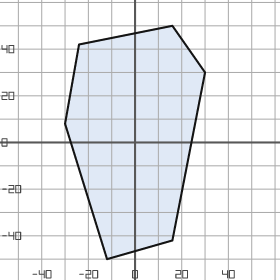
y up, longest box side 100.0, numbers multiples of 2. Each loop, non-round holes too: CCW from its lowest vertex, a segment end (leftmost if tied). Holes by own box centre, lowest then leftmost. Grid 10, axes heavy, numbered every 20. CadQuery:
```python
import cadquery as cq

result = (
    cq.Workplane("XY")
    .moveTo(-12.0, -50.0)
    .lineTo(16.0, -42.0)
    .lineTo(30.0, 30.0)
    .lineTo(16.0, 50.0)
    .lineTo(-24.0, 42.0)
    .lineTo(-30.0, 8.0)
    .close()
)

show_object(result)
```